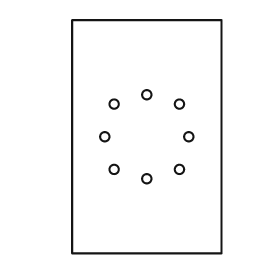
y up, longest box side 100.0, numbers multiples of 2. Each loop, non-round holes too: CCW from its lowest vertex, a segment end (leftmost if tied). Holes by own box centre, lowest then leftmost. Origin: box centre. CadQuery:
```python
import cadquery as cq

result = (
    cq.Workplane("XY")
    .moveTo(-32.0, -50.0)
    .lineTo(32.0, -50.0)
    .lineTo(32.0, 50.0)
    .lineTo(-32.0, 50.0)
    .close()
    .moveTo(0.0, -18.0)
    .circle(2.0)
    .moveTo(-14.0, -14.0)
    .circle(2.0)
    .moveTo(14.0, -14.0)
    .circle(2.0)
    .moveTo(-18.0, 0.0)
    .circle(2.0)
    .moveTo(18.0, 0.0)
    .circle(2.0)
    .moveTo(-14.0, 14.0)
    .circle(2.0)
    .moveTo(14.0, 14.0)
    .circle(2.0)
    .moveTo(0.0, 18.0)
    .circle(2.0)
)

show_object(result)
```